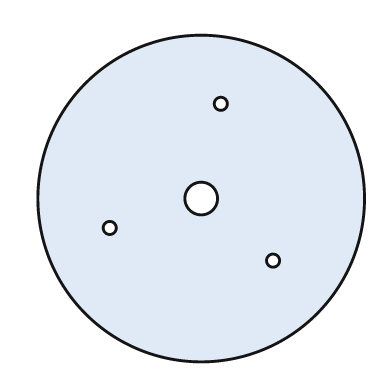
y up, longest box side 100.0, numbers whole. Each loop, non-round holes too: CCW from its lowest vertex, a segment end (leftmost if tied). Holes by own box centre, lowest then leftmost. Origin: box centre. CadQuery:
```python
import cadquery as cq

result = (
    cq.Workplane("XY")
    .moveTo(0.0, 0.0)
    .circle(50.0)
    .moveTo(22.0, -19.0)
    .circle(2.0)
    .moveTo(-28.0, -9.0)
    .circle(2.0)
    .moveTo(0.0, 0.0)
    .circle(5.0)
    .moveTo(6.0, 29.0)
    .circle(2.0)
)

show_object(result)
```